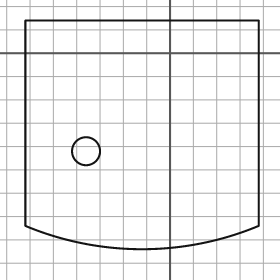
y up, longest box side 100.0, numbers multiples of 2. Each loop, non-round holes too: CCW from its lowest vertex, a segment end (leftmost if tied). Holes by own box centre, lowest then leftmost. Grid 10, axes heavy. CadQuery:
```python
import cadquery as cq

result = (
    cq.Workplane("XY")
    .moveTo(-62.0, -74.0)
    .threePointArc((-12.0, -84.0), (38.0, -74.0))
    .lineTo(38.0, 14.0)
    .lineTo(-62.0, 14.0)
    .close()
    .moveTo(-36.0, -42.0)
    .circle(6.0)
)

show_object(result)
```